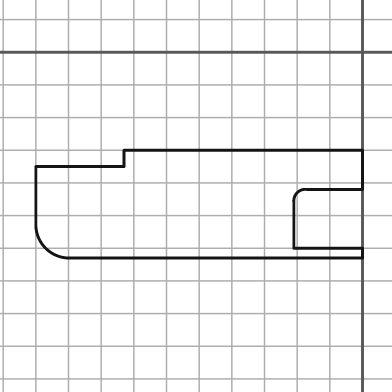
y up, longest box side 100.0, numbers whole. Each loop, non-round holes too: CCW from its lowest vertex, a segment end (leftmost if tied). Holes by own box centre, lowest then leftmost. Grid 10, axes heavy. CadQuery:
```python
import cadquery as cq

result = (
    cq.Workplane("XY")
    .moveTo(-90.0, -63.0)
    .lineTo(0.0, -63.0)
    .lineTo(0.0, -60.0)
    .lineTo(-21.0, -60.0)
    .lineTo(-21.0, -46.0)
    .threePointArc((-20.0, -43.0), (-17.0, -42.0))
    .lineTo(0.0, -42.0)
    .lineTo(0.0, -30.0)
    .lineTo(-73.0, -30.0)
    .lineTo(-73.0, -35.0)
    .lineTo(-100.0, -35.0)
    .lineTo(-100.0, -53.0)
    .threePointArc((-97.0, -60.0), (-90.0, -63.0))
    .close()
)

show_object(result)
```